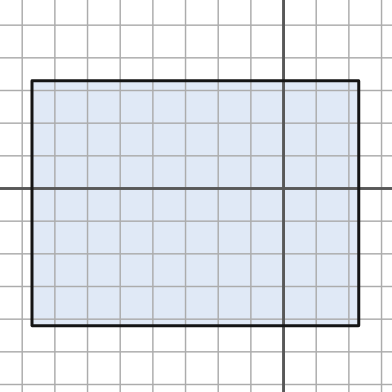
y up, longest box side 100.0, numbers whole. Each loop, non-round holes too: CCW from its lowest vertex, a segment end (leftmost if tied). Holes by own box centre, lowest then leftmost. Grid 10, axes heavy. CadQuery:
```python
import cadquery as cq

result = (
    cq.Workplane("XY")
    .moveTo(-77.0, -42.0)
    .lineTo(23.0, -42.0)
    .lineTo(23.0, 33.0)
    .lineTo(-77.0, 33.0)
    .close()
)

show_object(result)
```